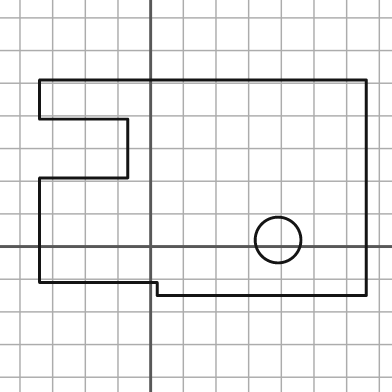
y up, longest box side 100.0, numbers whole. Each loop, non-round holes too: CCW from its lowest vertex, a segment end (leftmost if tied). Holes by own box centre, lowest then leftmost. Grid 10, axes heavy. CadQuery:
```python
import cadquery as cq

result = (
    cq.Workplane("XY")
    .moveTo(2.0, -15.0)
    .lineTo(66.0, -15.0)
    .lineTo(66.0, 51.0)
    .lineTo(-34.0, 51.0)
    .lineTo(-34.0, 39.0)
    .lineTo(-7.0, 39.0)
    .lineTo(-7.0, 21.0)
    .lineTo(-34.0, 21.0)
    .lineTo(-34.0, -11.0)
    .lineTo(2.0, -11.0)
    .close()
    .moveTo(39.0, 2.0)
    .circle(7.0)
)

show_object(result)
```